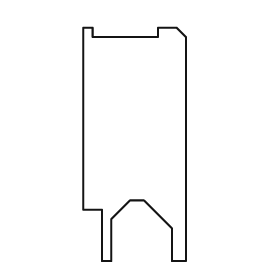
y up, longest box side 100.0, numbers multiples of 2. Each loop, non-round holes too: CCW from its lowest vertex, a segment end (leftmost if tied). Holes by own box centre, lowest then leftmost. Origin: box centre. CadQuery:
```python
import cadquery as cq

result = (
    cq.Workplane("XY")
    .moveTo(-14.0, -50.0)
    .lineTo(-10.0, -50.0)
    .lineTo(-10.0, -32.0)
    .lineTo(-2.0, -24.0)
    .lineTo(4.0, -24.0)
    .lineTo(16.0, -36.0)
    .lineTo(16.0, -50.0)
    .lineTo(22.0, -50.0)
    .lineTo(22.0, 46.0)
    .lineTo(18.0, 50.0)
    .lineTo(10.0, 50.0)
    .lineTo(10.0, 46.0)
    .lineTo(-18.0, 46.0)
    .lineTo(-18.0, 50.0)
    .lineTo(-22.0, 50.0)
    .lineTo(-22.0, -28.0)
    .lineTo(-14.0, -28.0)
    .close()
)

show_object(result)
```